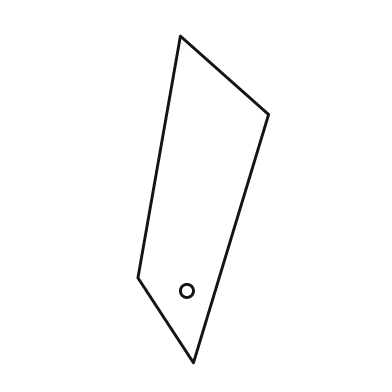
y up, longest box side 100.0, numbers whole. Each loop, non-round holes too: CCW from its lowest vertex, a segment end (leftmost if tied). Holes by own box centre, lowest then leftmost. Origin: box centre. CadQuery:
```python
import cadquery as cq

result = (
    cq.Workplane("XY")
    .moveTo(-3.0, -50.0)
    .lineTo(20.0, 26.0)
    .lineTo(-7.0, 50.0)
    .lineTo(-20.0, -24.0)
    .close()
    .moveTo(-5.0, -28.0)
    .circle(2.0)
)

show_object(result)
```